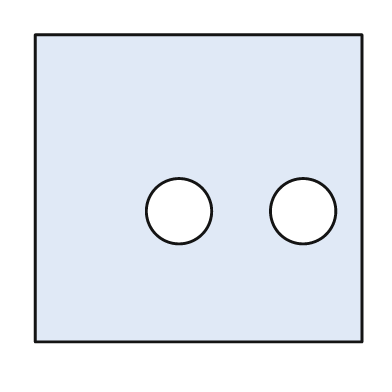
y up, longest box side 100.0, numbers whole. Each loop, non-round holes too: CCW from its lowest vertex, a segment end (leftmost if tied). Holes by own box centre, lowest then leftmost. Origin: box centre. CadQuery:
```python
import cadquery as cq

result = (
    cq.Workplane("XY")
    .moveTo(-50.0, -47.0)
    .lineTo(50.0, -47.0)
    .lineTo(50.0, 47.0)
    .lineTo(-50.0, 47.0)
    .close()
    .moveTo(-6.0, -7.0)
    .circle(10.0)
    .moveTo(32.0, -7.0)
    .circle(10.0)
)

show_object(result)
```